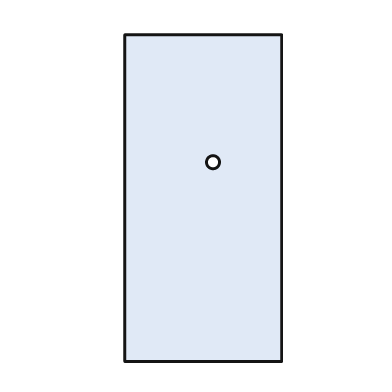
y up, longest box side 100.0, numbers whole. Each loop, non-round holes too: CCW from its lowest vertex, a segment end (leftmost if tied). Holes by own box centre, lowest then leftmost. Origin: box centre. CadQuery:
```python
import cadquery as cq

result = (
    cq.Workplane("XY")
    .moveTo(-24.0, -50.0)
    .lineTo(24.0, -50.0)
    .lineTo(24.0, 50.0)
    .lineTo(-24.0, 50.0)
    .close()
    .moveTo(3.0, 11.0)
    .circle(2.0)
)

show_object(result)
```